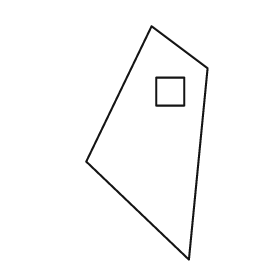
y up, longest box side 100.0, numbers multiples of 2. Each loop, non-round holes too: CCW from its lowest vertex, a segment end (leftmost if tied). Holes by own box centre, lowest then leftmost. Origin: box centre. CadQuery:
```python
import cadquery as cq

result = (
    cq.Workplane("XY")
    .moveTo(18.0, -50.0)
    .lineTo(26.0, 32.0)
    .lineTo(2.0, 50.0)
    .lineTo(-26.0, -8.0)
    .close()
    .moveTo(4.0, 16.0)
    .lineTo(16.0, 16.0)
    .lineTo(16.0, 28.0)
    .lineTo(4.0, 28.0)
    .close()
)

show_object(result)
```